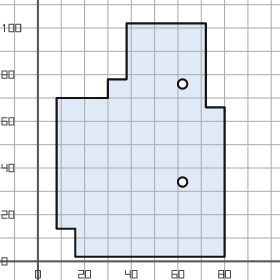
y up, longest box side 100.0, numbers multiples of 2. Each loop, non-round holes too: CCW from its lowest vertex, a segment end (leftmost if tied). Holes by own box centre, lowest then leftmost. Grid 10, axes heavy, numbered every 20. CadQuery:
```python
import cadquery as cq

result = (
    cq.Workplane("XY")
    .moveTo(16.0, 2.0)
    .lineTo(80.0, 2.0)
    .lineTo(80.0, 66.0)
    .lineTo(72.0, 66.0)
    .lineTo(72.0, 102.0)
    .lineTo(38.0, 102.0)
    .lineTo(38.0, 78.0)
    .lineTo(30.0, 78.0)
    .lineTo(30.0, 70.0)
    .lineTo(8.0, 70.0)
    .lineTo(8.0, 14.0)
    .lineTo(16.0, 14.0)
    .close()
    .moveTo(62.0, 34.0)
    .circle(2.0)
    .moveTo(62.0, 76.0)
    .circle(2.0)
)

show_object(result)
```